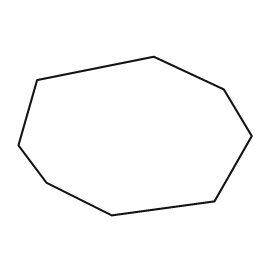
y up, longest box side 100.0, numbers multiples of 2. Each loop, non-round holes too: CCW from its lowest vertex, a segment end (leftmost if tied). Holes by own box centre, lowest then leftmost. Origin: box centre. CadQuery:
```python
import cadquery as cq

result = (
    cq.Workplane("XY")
    .moveTo(-10.0, -34.0)
    .lineTo(34.0, -28.0)
    .lineTo(50.0, 0.0)
    .lineTo(38.0, 20.0)
    .lineTo(8.0, 34.0)
    .lineTo(-42.0, 24.0)
    .lineTo(-50.0, -4.0)
    .lineTo(-38.0, -20.0)
    .close()
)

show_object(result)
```